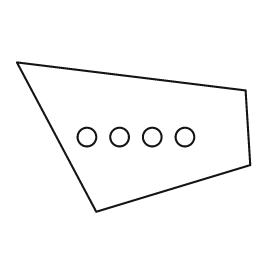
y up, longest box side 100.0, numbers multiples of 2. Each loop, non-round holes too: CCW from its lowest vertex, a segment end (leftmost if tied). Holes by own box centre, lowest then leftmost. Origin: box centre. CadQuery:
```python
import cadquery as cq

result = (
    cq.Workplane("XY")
    .moveTo(-16.0, -32.0)
    .lineTo(50.0, -12.0)
    .lineTo(48.0, 20.0)
    .lineTo(-50.0, 32.0)
    .close()
    .moveTo(-20.0, 0.0)
    .circle(4.0)
    .moveTo(-6.0, 0.0)
    .circle(4.0)
    .moveTo(8.0, 0.0)
    .circle(4.0)
    .moveTo(22.0, 0.0)
    .circle(4.0)
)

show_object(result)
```